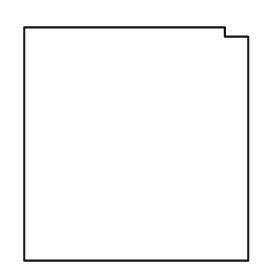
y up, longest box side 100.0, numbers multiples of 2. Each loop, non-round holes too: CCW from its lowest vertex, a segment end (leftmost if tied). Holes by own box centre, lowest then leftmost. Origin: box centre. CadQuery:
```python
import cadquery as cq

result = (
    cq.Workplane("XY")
    .moveTo(-48.0, -50.0)
    .lineTo(48.0, -50.0)
    .lineTo(48.0, 46.0)
    .lineTo(38.0, 46.0)
    .lineTo(38.0, 50.0)
    .lineTo(-48.0, 50.0)
    .close()
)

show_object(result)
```